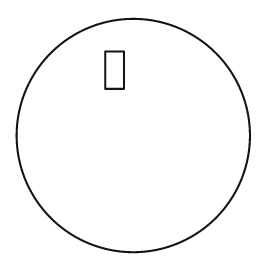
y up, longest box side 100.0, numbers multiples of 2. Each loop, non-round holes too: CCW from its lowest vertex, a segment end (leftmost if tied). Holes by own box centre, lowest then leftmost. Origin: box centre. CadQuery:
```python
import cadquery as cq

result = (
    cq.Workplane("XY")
    .moveTo(0.0, 0.0)
    .circle(50.0)
    .moveTo(-12.0, 20.0)
    .lineTo(-4.0, 20.0)
    .lineTo(-4.0, 36.0)
    .lineTo(-12.0, 36.0)
    .close()
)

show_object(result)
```